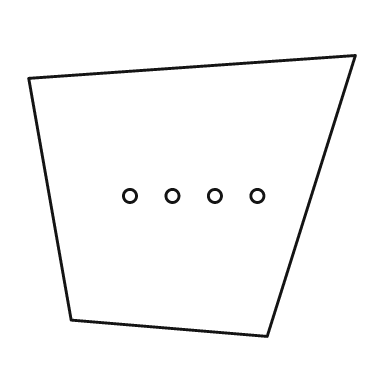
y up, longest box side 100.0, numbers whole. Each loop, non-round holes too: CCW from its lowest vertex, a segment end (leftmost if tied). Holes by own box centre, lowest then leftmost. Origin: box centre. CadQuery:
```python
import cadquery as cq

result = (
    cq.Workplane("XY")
    .moveTo(23.0, -43.0)
    .lineTo(50.0, 43.0)
    .lineTo(-50.0, 36.0)
    .lineTo(-37.0, -38.0)
    .close()
    .moveTo(-19.0, 0.0)
    .circle(2.0)
    .moveTo(-6.0, 0.0)
    .circle(2.0)
    .moveTo(7.0, 0.0)
    .circle(2.0)
    .moveTo(20.0, 0.0)
    .circle(2.0)
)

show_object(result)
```